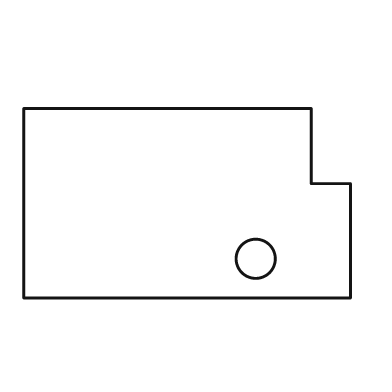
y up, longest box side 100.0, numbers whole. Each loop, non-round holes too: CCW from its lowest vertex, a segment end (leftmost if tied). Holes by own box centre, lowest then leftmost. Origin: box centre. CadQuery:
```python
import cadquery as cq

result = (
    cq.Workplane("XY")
    .moveTo(-50.0, -29.0)
    .lineTo(50.0, -29.0)
    .lineTo(50.0, 6.0)
    .lineTo(38.0, 6.0)
    .lineTo(38.0, 29.0)
    .lineTo(-50.0, 29.0)
    .close()
    .moveTo(21.0, -17.0)
    .circle(6.0)
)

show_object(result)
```